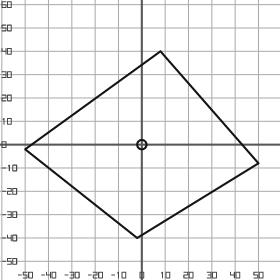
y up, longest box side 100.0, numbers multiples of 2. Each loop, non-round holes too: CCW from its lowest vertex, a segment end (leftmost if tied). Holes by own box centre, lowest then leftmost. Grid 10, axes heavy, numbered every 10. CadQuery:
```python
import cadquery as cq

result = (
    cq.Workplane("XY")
    .moveTo(-2.0, -40.0)
    .lineTo(50.0, -8.0)
    .lineTo(8.0, 40.0)
    .lineTo(-50.0, -2.0)
    .close()
    .moveTo(0.0, 0.0)
    .circle(2.0)
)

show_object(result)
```